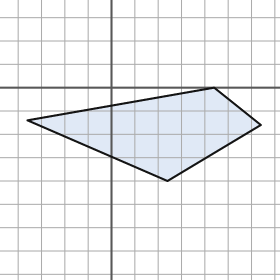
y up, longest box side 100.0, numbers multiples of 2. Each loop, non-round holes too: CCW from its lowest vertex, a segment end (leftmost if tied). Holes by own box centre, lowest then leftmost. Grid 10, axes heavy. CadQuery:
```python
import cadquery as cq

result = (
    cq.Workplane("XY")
    .moveTo(24.0, -40.0)
    .lineTo(64.0, -16.0)
    .lineTo(44.0, 0.0)
    .lineTo(-36.0, -14.0)
    .close()
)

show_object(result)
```